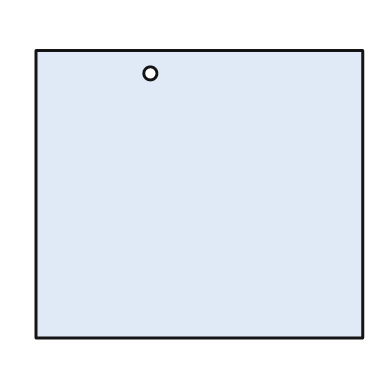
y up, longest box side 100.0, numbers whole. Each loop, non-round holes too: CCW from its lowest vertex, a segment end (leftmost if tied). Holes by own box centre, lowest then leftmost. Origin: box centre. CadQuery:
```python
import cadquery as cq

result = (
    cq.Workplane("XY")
    .moveTo(-50.0, -44.0)
    .lineTo(50.0, -44.0)
    .lineTo(50.0, 44.0)
    .lineTo(-50.0, 44.0)
    .close()
    .moveTo(-15.0, 37.0)
    .circle(2.0)
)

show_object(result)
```